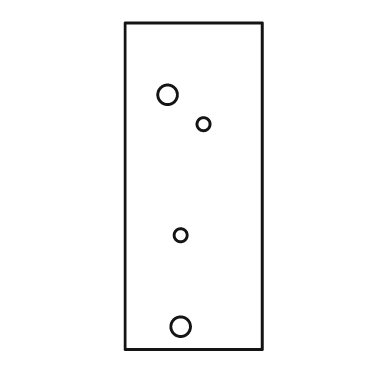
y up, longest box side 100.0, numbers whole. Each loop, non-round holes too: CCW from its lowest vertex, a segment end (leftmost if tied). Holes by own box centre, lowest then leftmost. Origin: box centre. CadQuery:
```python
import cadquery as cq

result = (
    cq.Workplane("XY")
    .moveTo(-21.0, -50.0)
    .lineTo(21.0, -50.0)
    .lineTo(21.0, 50.0)
    .lineTo(-21.0, 50.0)
    .close()
    .moveTo(-4.0, -43.0)
    .circle(3.0)
    .moveTo(-4.0, -15.0)
    .circle(2.0)
    .moveTo(3.0, 19.0)
    .circle(2.0)
    .moveTo(-8.0, 28.0)
    .circle(3.0)
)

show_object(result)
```